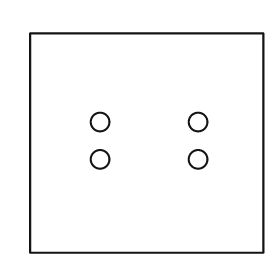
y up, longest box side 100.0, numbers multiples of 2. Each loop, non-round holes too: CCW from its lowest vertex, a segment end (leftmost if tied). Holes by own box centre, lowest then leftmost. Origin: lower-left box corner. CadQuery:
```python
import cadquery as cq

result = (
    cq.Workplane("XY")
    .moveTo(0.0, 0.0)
    .lineTo(100.0, 0.0)
    .lineTo(100.0, 94.0)
    .lineTo(0.0, 94.0)
    .close()
    .moveTo(30.0, 40.0)
    .circle(4.0)
    .moveTo(72.0, 40.0)
    .circle(4.0)
    .moveTo(30.0, 56.0)
    .circle(4.0)
    .moveTo(72.0, 56.0)
    .circle(4.0)
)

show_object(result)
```